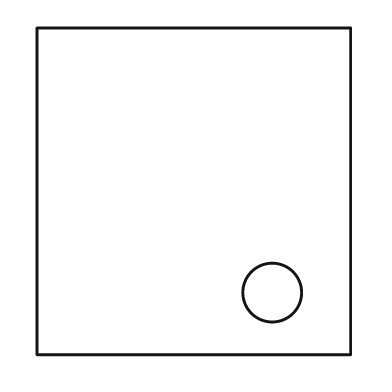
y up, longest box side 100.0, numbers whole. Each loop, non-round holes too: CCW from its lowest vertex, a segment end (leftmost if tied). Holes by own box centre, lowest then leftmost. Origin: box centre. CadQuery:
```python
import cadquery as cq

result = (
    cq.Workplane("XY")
    .moveTo(-48.0, -50.0)
    .lineTo(48.0, -50.0)
    .lineTo(48.0, 50.0)
    .lineTo(-48.0, 50.0)
    .close()
    .moveTo(24.0, -31.0)
    .circle(9.0)
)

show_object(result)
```